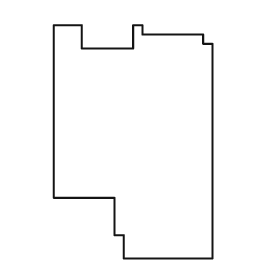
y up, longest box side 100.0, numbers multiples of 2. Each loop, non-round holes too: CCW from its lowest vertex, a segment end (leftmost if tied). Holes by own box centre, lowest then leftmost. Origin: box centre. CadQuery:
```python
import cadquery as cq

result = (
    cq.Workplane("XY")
    .moveTo(-4.0, -50.0)
    .lineTo(34.0, -50.0)
    .lineTo(34.0, 42.0)
    .lineTo(30.0, 42.0)
    .lineTo(30.0, 46.0)
    .lineTo(4.0, 46.0)
    .lineTo(4.0, 50.0)
    .lineTo(0.0, 50.0)
    .lineTo(0.0, 40.0)
    .lineTo(-22.0, 40.0)
    .lineTo(-22.0, 50.0)
    .lineTo(-34.0, 50.0)
    .lineTo(-34.0, -24.0)
    .lineTo(-8.0, -24.0)
    .lineTo(-8.0, -40.0)
    .lineTo(-4.0, -40.0)
    .close()
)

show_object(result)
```